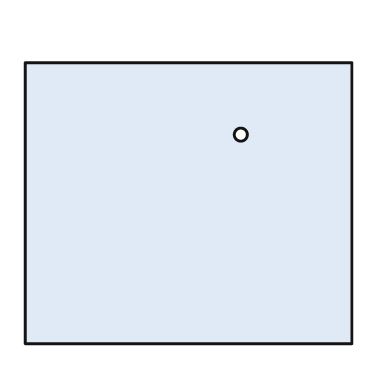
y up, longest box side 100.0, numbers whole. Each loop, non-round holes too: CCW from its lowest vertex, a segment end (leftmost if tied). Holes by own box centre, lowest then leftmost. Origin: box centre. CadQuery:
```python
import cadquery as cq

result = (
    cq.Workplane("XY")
    .moveTo(-50.0, -43.0)
    .lineTo(50.0, -43.0)
    .lineTo(50.0, 43.0)
    .lineTo(-50.0, 43.0)
    .close()
    .moveTo(16.0, 21.0)
    .circle(2.0)
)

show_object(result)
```